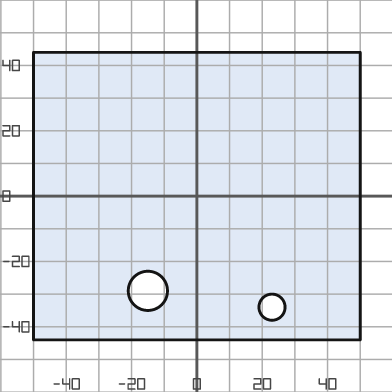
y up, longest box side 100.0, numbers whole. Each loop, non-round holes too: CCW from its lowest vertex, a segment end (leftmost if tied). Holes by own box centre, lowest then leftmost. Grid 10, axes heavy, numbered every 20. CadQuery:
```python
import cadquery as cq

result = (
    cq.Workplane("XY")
    .moveTo(-50.0, -44.0)
    .lineTo(50.0, -44.0)
    .lineTo(50.0, 44.0)
    .lineTo(-50.0, 44.0)
    .close()
    .moveTo(23.0, -34.0)
    .circle(4.0)
    .moveTo(-15.0, -29.0)
    .circle(6.0)
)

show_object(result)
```